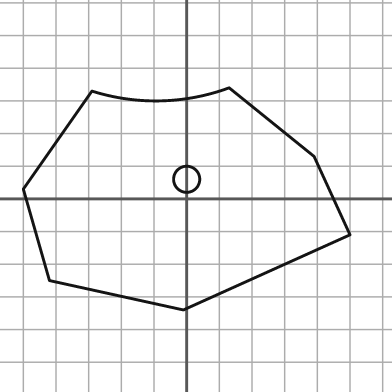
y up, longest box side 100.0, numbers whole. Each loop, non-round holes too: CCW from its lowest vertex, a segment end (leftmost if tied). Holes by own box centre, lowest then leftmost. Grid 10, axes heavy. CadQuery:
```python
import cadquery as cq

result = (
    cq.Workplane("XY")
    .moveTo(-1.0, -34.0)
    .lineTo(50.0, -11.0)
    .lineTo(39.0, 13.0)
    .lineTo(13.0, 34.0)
    .threePointArc((-8.0, 30.0), (-29.0, 33.0))
    .lineTo(-50.0, 3.0)
    .lineTo(-42.0, -25.0)
    .close()
    .moveTo(0.0, 6.0)
    .circle(4.0)
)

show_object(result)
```